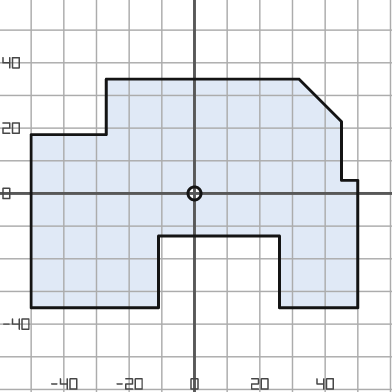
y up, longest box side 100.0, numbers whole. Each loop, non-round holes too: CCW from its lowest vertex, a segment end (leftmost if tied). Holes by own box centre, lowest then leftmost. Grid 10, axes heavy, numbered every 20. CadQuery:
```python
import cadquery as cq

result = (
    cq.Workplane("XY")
    .moveTo(-50.0, -35.0)
    .lineTo(-11.0, -35.0)
    .lineTo(-11.0, -13.0)
    .lineTo(26.0, -13.0)
    .lineTo(26.0, -35.0)
    .lineTo(50.0, -35.0)
    .lineTo(50.0, 4.0)
    .lineTo(45.0, 4.0)
    .lineTo(45.0, 22.0)
    .lineTo(32.0, 35.0)
    .lineTo(-27.0, 35.0)
    .lineTo(-27.0, 18.0)
    .lineTo(-50.0, 18.0)
    .close()
    .moveTo(0.0, 0.0)
    .circle(2.0)
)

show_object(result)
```